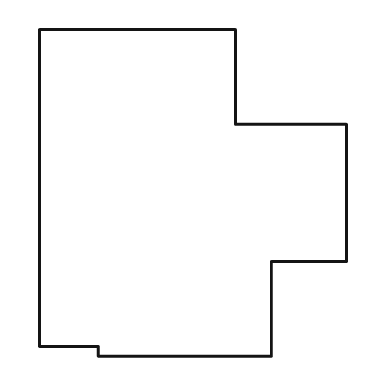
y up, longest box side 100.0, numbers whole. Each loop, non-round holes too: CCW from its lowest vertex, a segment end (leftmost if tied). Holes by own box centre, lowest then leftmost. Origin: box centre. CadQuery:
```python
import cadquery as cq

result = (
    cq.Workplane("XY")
    .moveTo(-29.0, -50.0)
    .lineTo(24.0, -50.0)
    .lineTo(24.0, -21.0)
    .lineTo(47.0, -21.0)
    .lineTo(47.0, 21.0)
    .lineTo(13.0, 21.0)
    .lineTo(13.0, 50.0)
    .lineTo(-47.0, 50.0)
    .lineTo(-47.0, -47.0)
    .lineTo(-29.0, -47.0)
    .close()
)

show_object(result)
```